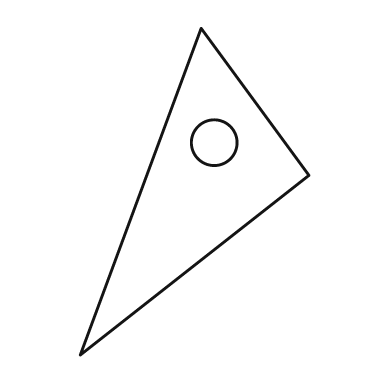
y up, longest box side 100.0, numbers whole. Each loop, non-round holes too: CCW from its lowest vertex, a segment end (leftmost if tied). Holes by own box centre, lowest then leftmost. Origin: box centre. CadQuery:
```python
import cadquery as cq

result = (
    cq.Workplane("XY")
    .moveTo(-35.0, -50.0)
    .lineTo(35.0, 5.0)
    .lineTo(2.0, 50.0)
    .close()
    .moveTo(6.0, 15.0)
    .circle(7.0)
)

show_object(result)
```